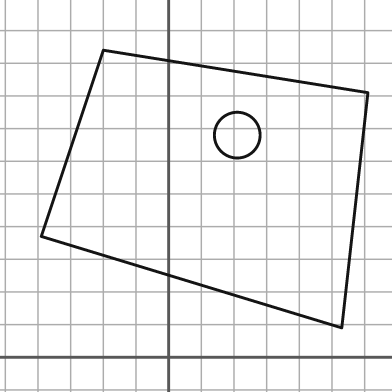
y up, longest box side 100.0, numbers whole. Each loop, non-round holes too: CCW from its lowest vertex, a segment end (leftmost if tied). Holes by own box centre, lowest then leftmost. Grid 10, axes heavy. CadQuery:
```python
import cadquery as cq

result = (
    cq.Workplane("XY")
    .moveTo(53.0, 9.0)
    .lineTo(61.0, 81.0)
    .lineTo(-20.0, 94.0)
    .lineTo(-39.0, 37.0)
    .close()
    .moveTo(21.0, 68.0)
    .circle(7.0)
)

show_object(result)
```